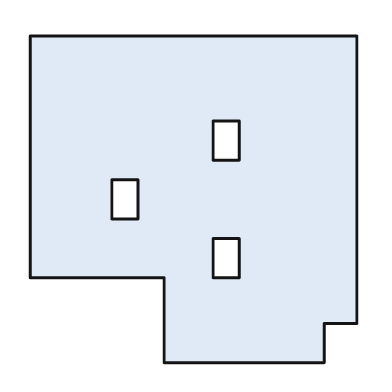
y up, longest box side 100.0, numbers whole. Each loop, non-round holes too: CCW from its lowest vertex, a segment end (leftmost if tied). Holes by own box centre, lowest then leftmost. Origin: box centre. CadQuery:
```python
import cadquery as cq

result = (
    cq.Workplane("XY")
    .moveTo(-9.0, -50.0)
    .lineTo(40.0, -50.0)
    .lineTo(40.0, -38.0)
    .lineTo(50.0, -38.0)
    .lineTo(50.0, 50.0)
    .lineTo(-50.0, 50.0)
    .lineTo(-50.0, -24.0)
    .lineTo(-9.0, -24.0)
    .close()
    .moveTo(6.0, -24.0)
    .lineTo(14.0, -24.0)
    .lineTo(14.0, -12.0)
    .lineTo(6.0, -12.0)
    .close()
    .moveTo(-25.0, -6.0)
    .lineTo(-17.0, -6.0)
    .lineTo(-17.0, 6.0)
    .lineTo(-25.0, 6.0)
    .close()
    .moveTo(6.0, 12.0)
    .lineTo(14.0, 12.0)
    .lineTo(14.0, 24.0)
    .lineTo(6.0, 24.0)
    .close()
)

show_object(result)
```